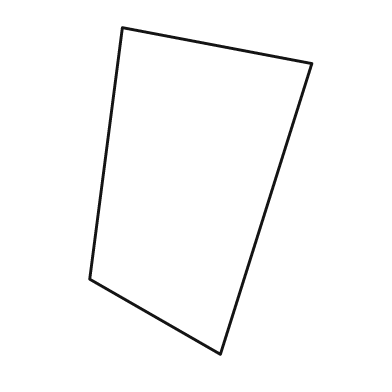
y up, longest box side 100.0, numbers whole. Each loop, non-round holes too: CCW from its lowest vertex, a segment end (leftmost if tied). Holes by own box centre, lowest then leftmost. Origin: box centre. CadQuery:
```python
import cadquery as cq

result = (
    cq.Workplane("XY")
    .moveTo(6.0, -50.0)
    .lineTo(34.0, 39.0)
    .lineTo(-24.0, 50.0)
    .lineTo(-34.0, -27.0)
    .close()
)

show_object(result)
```